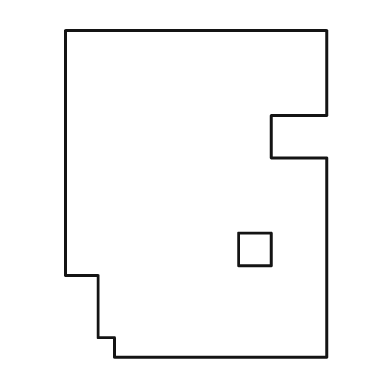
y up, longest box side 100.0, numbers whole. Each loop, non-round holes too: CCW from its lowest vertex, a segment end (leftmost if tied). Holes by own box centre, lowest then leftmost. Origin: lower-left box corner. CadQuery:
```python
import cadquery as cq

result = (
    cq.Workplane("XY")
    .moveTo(15.0, 0.0)
    .lineTo(80.0, 0.0)
    .lineTo(80.0, 61.0)
    .lineTo(63.0, 61.0)
    .lineTo(63.0, 74.0)
    .lineTo(80.0, 74.0)
    .lineTo(80.0, 100.0)
    .lineTo(0.0, 100.0)
    .lineTo(0.0, 25.0)
    .lineTo(10.0, 25.0)
    .lineTo(10.0, 6.0)
    .lineTo(15.0, 6.0)
    .close()
    .moveTo(53.0, 28.0)
    .lineTo(63.0, 28.0)
    .lineTo(63.0, 38.0)
    .lineTo(53.0, 38.0)
    .close()
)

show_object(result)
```